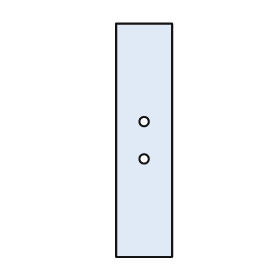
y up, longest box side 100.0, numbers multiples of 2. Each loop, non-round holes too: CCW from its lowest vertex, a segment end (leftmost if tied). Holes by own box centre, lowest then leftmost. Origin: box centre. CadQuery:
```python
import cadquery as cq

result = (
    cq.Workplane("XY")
    .moveTo(-12.0, -50.0)
    .lineTo(12.0, -50.0)
    .lineTo(12.0, 50.0)
    .lineTo(-12.0, 50.0)
    .close()
    .moveTo(0.0, -8.0)
    .circle(2.0)
    .moveTo(0.0, 8.0)
    .circle(2.0)
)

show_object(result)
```